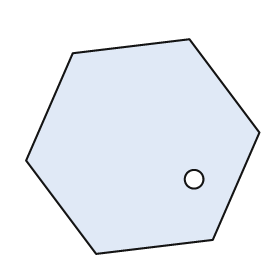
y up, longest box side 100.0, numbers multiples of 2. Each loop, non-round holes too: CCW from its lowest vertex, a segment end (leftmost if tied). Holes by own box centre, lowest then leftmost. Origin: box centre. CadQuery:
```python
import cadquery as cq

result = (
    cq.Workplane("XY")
    .moveTo(-20.0, -46.0)
    .lineTo(30.0, -40.0)
    .lineTo(50.0, 6.0)
    .lineTo(20.0, 46.0)
    .lineTo(-30.0, 40.0)
    .lineTo(-50.0, -6.0)
    .close()
    .moveTo(22.0, -14.0)
    .circle(4.0)
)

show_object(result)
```